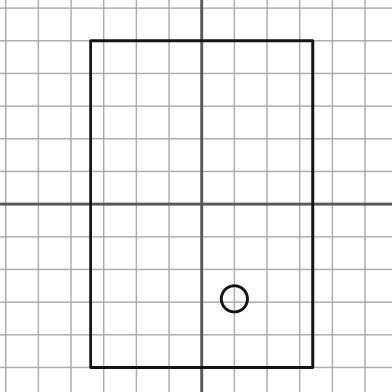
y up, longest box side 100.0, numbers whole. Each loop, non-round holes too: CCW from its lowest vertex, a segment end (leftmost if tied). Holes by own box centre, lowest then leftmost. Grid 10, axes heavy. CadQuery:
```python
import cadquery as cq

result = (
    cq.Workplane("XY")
    .moveTo(-34.0, -50.0)
    .lineTo(34.0, -50.0)
    .lineTo(34.0, 50.0)
    .lineTo(-34.0, 50.0)
    .close()
    .moveTo(10.0, -29.0)
    .circle(4.0)
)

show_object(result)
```